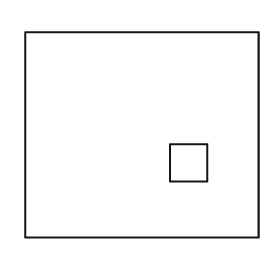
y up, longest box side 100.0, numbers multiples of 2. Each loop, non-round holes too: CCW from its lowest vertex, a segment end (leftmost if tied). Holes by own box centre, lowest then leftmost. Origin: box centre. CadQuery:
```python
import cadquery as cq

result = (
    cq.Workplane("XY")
    .moveTo(-50.0, -44.0)
    .lineTo(50.0, -44.0)
    .lineTo(50.0, 44.0)
    .lineTo(-50.0, 44.0)
    .close()
    .moveTo(12.0, -20.0)
    .lineTo(28.0, -20.0)
    .lineTo(28.0, -4.0)
    .lineTo(12.0, -4.0)
    .close()
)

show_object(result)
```